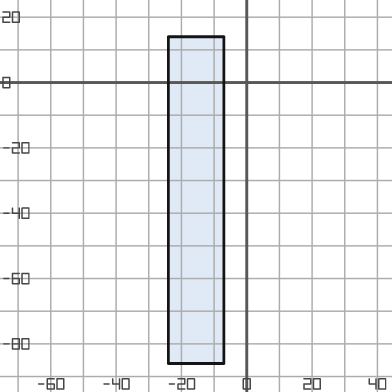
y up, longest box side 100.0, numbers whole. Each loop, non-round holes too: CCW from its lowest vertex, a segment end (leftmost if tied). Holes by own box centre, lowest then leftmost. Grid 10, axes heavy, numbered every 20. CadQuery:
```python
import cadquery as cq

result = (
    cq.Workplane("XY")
    .moveTo(-24.0, -86.0)
    .lineTo(-7.0, -86.0)
    .lineTo(-7.0, 14.0)
    .lineTo(-24.0, 14.0)
    .close()
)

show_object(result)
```